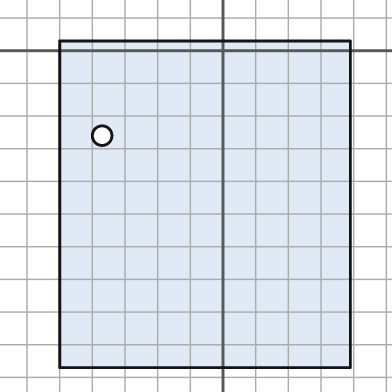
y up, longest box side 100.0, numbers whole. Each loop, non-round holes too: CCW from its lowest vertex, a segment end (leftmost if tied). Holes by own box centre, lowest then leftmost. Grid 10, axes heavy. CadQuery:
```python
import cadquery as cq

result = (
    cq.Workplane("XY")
    .moveTo(-50.0, -97.0)
    .lineTo(39.0, -97.0)
    .lineTo(39.0, 3.0)
    .lineTo(-50.0, 3.0)
    .close()
    .moveTo(-37.0, -26.0)
    .circle(3.0)
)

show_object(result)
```